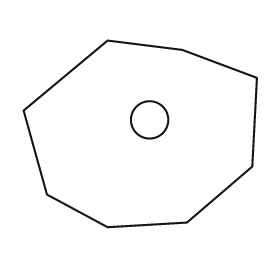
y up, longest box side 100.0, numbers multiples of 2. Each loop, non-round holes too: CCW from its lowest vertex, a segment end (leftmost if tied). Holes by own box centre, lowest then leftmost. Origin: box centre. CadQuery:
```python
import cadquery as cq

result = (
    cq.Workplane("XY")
    .moveTo(-14.0, -40.0)
    .lineTo(20.0, -38.0)
    .lineTo(48.0, -14.0)
    .lineTo(50.0, 24.0)
    .lineTo(18.0, 36.0)
    .lineTo(-14.0, 40.0)
    .lineTo(-50.0, 10.0)
    .lineTo(-40.0, -26.0)
    .close()
    .moveTo(4.0, 6.0)
    .circle(8.0)
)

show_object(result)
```